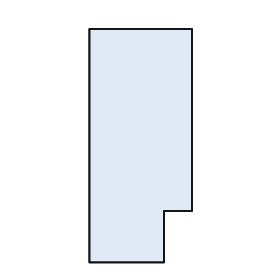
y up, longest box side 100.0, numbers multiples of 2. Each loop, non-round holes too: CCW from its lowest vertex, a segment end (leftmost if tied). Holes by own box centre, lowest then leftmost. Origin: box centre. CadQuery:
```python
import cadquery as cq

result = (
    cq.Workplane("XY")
    .moveTo(-22.0, -50.0)
    .lineTo(10.0, -50.0)
    .lineTo(10.0, -28.0)
    .lineTo(22.0, -28.0)
    .lineTo(22.0, 50.0)
    .lineTo(-22.0, 50.0)
    .close()
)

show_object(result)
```